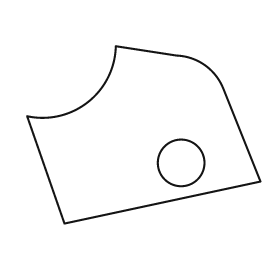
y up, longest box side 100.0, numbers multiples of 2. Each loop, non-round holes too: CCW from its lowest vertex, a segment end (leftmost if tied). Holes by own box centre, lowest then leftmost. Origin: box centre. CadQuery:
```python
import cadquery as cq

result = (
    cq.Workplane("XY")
    .moveTo(-34.0, -38.0)
    .lineTo(50.0, -20.0)
    .lineTo(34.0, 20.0)
    .threePointArc((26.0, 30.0), (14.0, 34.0))
    .lineTo(-12.0, 38.0)
    .threePointArc((-24.0, 14.0), (-50.0, 8.0))
    .close()
    .moveTo(16.0, -12.0)
    .circle(10.0)
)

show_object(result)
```